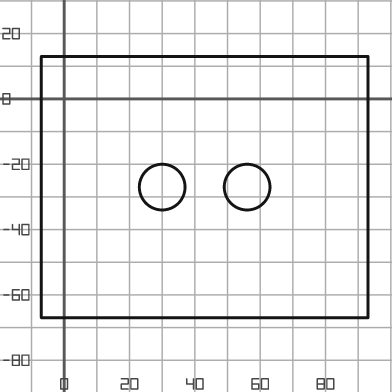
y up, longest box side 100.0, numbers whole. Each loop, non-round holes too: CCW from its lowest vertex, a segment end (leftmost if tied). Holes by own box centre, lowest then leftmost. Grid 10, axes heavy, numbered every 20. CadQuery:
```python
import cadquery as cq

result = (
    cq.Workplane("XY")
    .moveTo(-7.0, -67.0)
    .lineTo(93.0, -67.0)
    .lineTo(93.0, 13.0)
    .lineTo(-7.0, 13.0)
    .close()
    .moveTo(30.0, -27.0)
    .circle(7.0)
    .moveTo(56.0, -27.0)
    .circle(7.0)
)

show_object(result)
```